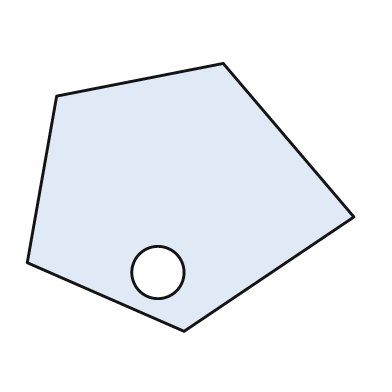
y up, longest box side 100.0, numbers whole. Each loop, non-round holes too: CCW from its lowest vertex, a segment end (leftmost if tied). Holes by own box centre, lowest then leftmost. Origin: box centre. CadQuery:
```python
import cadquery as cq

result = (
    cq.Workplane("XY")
    .moveTo(-2.0, -41.0)
    .lineTo(50.0, -6.0)
    .lineTo(10.0, 41.0)
    .lineTo(-41.0, 31.0)
    .lineTo(-50.0, -20.0)
    .close()
    .moveTo(-10.0, -23.0)
    .circle(8.0)
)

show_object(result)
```